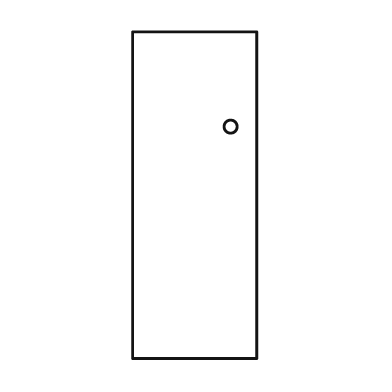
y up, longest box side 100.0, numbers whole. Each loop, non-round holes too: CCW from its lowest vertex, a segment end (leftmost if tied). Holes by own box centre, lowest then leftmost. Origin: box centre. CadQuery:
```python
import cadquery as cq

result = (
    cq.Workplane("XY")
    .moveTo(-19.0, -50.0)
    .lineTo(19.0, -50.0)
    .lineTo(19.0, 50.0)
    .lineTo(-19.0, 50.0)
    .close()
    .moveTo(11.0, 21.0)
    .circle(2.0)
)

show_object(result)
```